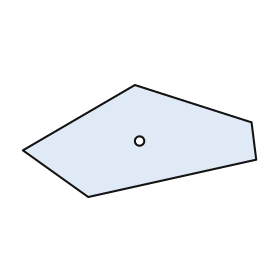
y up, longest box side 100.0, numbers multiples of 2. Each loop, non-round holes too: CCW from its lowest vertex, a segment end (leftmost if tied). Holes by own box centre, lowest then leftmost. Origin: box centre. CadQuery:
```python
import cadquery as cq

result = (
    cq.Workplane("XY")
    .moveTo(-22.0, -24.0)
    .lineTo(50.0, -8.0)
    .lineTo(48.0, 8.0)
    .lineTo(-2.0, 24.0)
    .lineTo(-50.0, -4.0)
    .close()
    .moveTo(0.0, 0.0)
    .circle(2.0)
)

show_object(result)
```